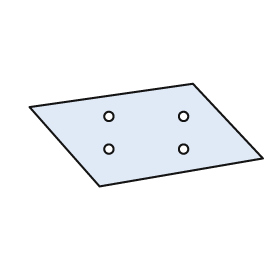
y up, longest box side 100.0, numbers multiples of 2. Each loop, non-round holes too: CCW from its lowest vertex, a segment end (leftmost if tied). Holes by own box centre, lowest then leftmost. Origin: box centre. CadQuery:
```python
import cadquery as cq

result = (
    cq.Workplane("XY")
    .moveTo(-20.0, -22.0)
    .lineTo(50.0, -10.0)
    .lineTo(20.0, 22.0)
    .lineTo(-50.0, 12.0)
    .close()
    .moveTo(-16.0, -6.0)
    .circle(2.0)
    .moveTo(16.0, -6.0)
    .circle(2.0)
    .moveTo(-16.0, 8.0)
    .circle(2.0)
    .moveTo(16.0, 8.0)
    .circle(2.0)
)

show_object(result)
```